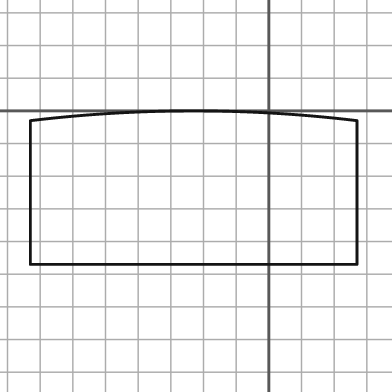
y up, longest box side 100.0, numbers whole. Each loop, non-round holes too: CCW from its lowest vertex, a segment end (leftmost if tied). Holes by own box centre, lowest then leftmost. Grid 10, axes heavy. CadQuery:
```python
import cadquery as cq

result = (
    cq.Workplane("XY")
    .moveTo(-73.0, -47.0)
    .lineTo(27.0, -47.0)
    .lineTo(27.0, -3.0)
    .threePointArc((-23.0, 0.0), (-73.0, -3.0))
    .close()
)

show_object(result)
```